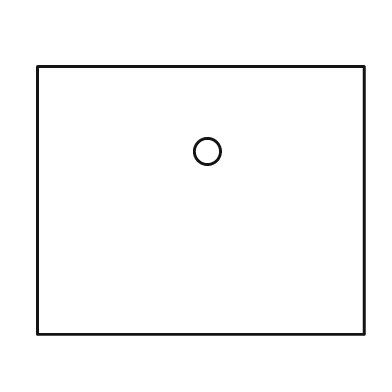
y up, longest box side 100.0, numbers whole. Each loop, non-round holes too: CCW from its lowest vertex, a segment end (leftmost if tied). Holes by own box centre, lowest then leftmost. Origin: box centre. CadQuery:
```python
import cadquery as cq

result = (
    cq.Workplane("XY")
    .moveTo(-50.0, -41.0)
    .lineTo(50.0, -41.0)
    .lineTo(50.0, 41.0)
    .lineTo(-50.0, 41.0)
    .close()
    .moveTo(2.0, 15.0)
    .circle(4.0)
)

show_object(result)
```